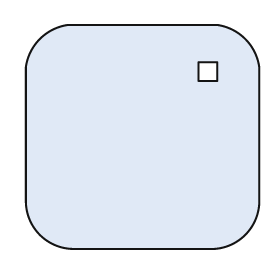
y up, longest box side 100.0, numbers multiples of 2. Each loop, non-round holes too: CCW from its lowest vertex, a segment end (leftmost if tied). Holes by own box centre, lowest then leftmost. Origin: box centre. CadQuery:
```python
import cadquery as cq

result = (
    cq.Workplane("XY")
    .moveTo(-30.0, -48.0)
    .lineTo(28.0, -48.0)
    .threePointArc((44.0, -42.0), (50.0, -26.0))
    .lineTo(50.0, 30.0)
    .threePointArc((44.0, 42.0), (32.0, 48.0))
    .lineTo(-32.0, 48.0)
    .threePointArc((-44.0, 42.0), (-50.0, 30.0))
    .lineTo(-50.0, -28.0)
    .threePointArc((-44.0, -42.0), (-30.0, -48.0))
    .close()
    .moveTo(24.0, 24.0)
    .lineTo(32.0, 24.0)
    .lineTo(32.0, 32.0)
    .lineTo(24.0, 32.0)
    .close()
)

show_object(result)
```